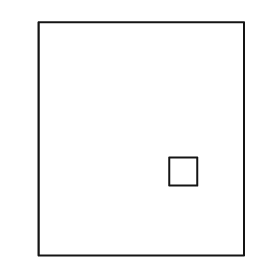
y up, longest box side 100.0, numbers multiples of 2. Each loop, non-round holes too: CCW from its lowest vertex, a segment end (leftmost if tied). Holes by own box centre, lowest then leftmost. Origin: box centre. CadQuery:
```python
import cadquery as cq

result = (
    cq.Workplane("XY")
    .moveTo(-44.0, -50.0)
    .lineTo(44.0, -50.0)
    .lineTo(44.0, 50.0)
    .lineTo(-44.0, 50.0)
    .close()
    .moveTo(12.0, -20.0)
    .lineTo(24.0, -20.0)
    .lineTo(24.0, -8.0)
    .lineTo(12.0, -8.0)
    .close()
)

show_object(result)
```